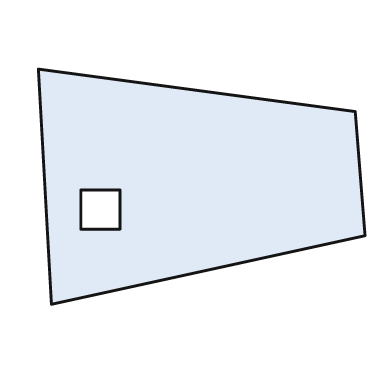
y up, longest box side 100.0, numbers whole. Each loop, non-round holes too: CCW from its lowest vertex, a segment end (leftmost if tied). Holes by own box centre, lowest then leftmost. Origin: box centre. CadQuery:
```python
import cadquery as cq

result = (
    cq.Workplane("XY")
    .moveTo(-46.0, -36.0)
    .lineTo(50.0, -15.0)
    .lineTo(47.0, 23.0)
    .lineTo(-50.0, 36.0)
    .close()
    .moveTo(-37.0, -13.0)
    .lineTo(-25.0, -13.0)
    .lineTo(-25.0, -1.0)
    .lineTo(-37.0, -1.0)
    .close()
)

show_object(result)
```